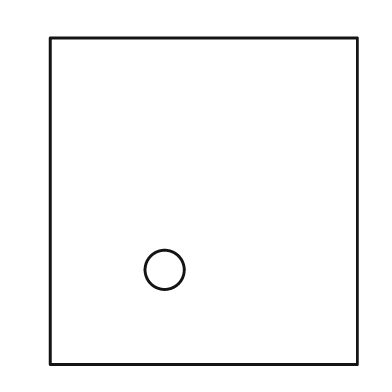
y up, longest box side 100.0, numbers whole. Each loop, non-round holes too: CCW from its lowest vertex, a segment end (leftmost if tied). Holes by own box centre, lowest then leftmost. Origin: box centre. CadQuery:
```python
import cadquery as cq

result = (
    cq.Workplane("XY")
    .moveTo(-47.0, -50.0)
    .lineTo(47.0, -50.0)
    .lineTo(47.0, 50.0)
    .lineTo(-47.0, 50.0)
    .close()
    .moveTo(-12.0, -21.0)
    .circle(6.0)
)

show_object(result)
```